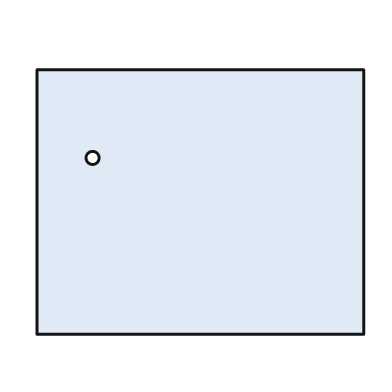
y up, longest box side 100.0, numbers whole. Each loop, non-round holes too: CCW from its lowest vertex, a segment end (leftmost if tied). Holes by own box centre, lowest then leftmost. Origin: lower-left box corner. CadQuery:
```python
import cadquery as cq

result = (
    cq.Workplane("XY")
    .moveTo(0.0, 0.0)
    .lineTo(100.0, 0.0)
    .lineTo(100.0, 81.0)
    .lineTo(0.0, 81.0)
    .close()
    .moveTo(17.0, 54.0)
    .circle(2.0)
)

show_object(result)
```